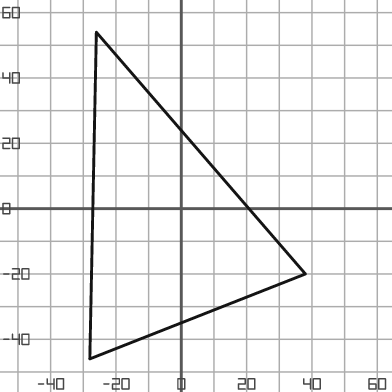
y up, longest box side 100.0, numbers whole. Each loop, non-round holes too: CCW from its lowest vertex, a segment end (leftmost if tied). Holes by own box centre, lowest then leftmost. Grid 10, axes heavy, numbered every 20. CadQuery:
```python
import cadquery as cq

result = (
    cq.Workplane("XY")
    .moveTo(-28.0, -46.0)
    .lineTo(38.0, -20.0)
    .lineTo(-26.0, 54.0)
    .close()
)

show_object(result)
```